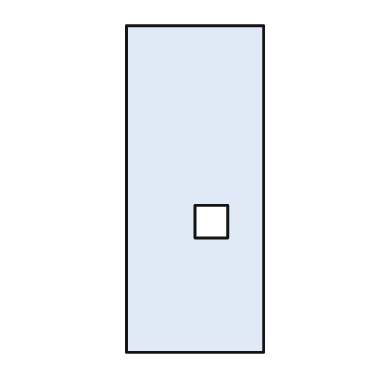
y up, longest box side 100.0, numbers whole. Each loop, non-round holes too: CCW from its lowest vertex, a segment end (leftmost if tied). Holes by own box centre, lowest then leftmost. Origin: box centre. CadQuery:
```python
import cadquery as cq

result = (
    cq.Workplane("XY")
    .moveTo(-21.0, -50.0)
    .lineTo(21.0, -50.0)
    .lineTo(21.0, 50.0)
    .lineTo(-21.0, 50.0)
    .close()
    .moveTo(0.0, -15.0)
    .lineTo(10.0, -15.0)
    .lineTo(10.0, -5.0)
    .lineTo(0.0, -5.0)
    .close()
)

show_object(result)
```